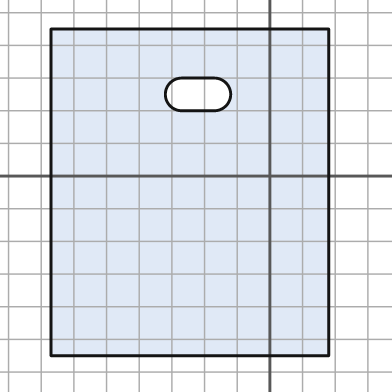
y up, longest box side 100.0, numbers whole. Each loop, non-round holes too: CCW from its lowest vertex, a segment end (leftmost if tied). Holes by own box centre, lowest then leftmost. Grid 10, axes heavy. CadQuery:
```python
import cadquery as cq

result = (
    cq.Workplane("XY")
    .moveTo(-67.0, -55.0)
    .lineTo(18.0, -55.0)
    .lineTo(18.0, 45.0)
    .lineTo(-67.0, 45.0)
    .close()
    .moveTo(-27.0, 20.0)
    .lineTo(-17.0, 20.0)
    .threePointArc((-12.0, 25.0), (-17.0, 30.0))
    .lineTo(-27.0, 30.0)
    .threePointArc((-32.0, 25.0), (-27.0, 20.0))
    .close()
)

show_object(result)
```